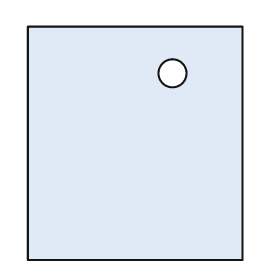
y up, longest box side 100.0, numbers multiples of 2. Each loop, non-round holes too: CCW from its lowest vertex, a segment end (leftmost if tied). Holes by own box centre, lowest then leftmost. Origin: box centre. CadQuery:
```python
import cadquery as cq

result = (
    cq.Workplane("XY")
    .moveTo(-46.0, -50.0)
    .lineTo(46.0, -50.0)
    .lineTo(46.0, 50.0)
    .lineTo(-46.0, 50.0)
    .close()
    .moveTo(16.0, 30.0)
    .circle(6.0)
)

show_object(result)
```